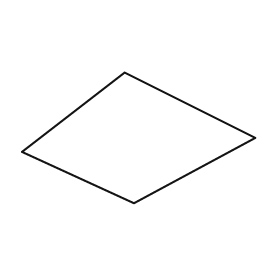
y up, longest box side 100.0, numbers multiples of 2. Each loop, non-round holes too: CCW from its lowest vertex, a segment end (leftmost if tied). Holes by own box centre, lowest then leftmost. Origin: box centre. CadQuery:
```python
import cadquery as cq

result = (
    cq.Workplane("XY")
    .moveTo(-2.0, -28.0)
    .lineTo(50.0, 0.0)
    .lineTo(-6.0, 28.0)
    .lineTo(-50.0, -6.0)
    .close()
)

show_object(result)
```